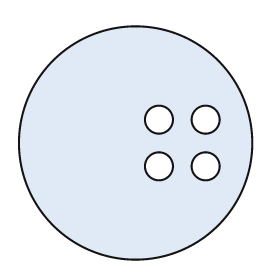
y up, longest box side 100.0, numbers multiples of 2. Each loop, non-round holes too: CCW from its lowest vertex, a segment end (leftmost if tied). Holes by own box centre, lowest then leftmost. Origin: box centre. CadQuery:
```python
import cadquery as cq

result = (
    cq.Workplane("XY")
    .moveTo(0.0, 0.0)
    .circle(50.0)
    .moveTo(10.0, -10.0)
    .circle(6.0)
    .moveTo(30.0, -10.0)
    .circle(6.0)
    .moveTo(10.0, 10.0)
    .circle(6.0)
    .moveTo(30.0, 10.0)
    .circle(6.0)
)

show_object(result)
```